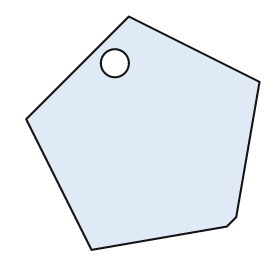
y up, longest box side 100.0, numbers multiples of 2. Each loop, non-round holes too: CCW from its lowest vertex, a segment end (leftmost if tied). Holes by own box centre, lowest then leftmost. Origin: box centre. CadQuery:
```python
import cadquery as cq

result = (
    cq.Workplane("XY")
    .moveTo(-22.0, -50.0)
    .lineTo(36.0, -40.0)
    .lineTo(40.0, -36.0)
    .lineTo(50.0, 22.0)
    .lineTo(-6.0, 50.0)
    .lineTo(-50.0, 6.0)
    .close()
    .moveTo(-12.0, 30.0)
    .circle(6.0)
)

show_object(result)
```